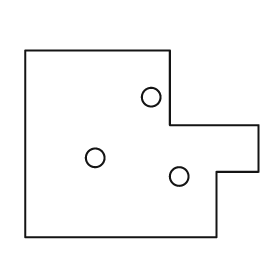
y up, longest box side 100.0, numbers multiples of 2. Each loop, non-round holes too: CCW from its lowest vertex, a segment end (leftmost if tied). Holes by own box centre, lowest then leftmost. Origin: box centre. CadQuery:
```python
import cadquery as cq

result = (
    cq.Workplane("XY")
    .moveTo(-50.0, -40.0)
    .lineTo(32.0, -40.0)
    .lineTo(32.0, -12.0)
    .lineTo(50.0, -12.0)
    .lineTo(50.0, 8.0)
    .lineTo(12.0, 8.0)
    .lineTo(12.0, 40.0)
    .lineTo(-50.0, 40.0)
    .close()
    .moveTo(16.0, -14.0)
    .circle(4.0)
    .moveTo(-20.0, -6.0)
    .circle(4.0)
    .moveTo(4.0, 20.0)
    .circle(4.0)
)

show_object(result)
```